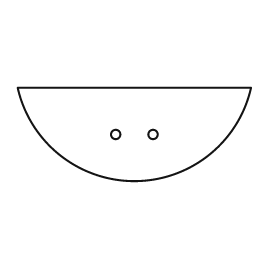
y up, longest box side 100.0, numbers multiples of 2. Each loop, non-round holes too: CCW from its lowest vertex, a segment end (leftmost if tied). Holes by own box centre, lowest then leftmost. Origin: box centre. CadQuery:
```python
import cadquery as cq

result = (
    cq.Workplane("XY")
    .moveTo(-50.0, 20.0)
    .threePointArc((0.0, -20.0), (50.0, 20.0))
    .close()
    .moveTo(-8.0, 0.0)
    .circle(2.0)
    .moveTo(8.0, 0.0)
    .circle(2.0)
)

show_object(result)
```